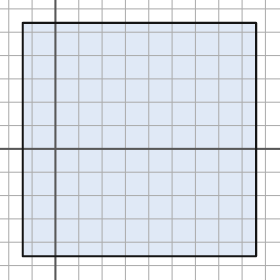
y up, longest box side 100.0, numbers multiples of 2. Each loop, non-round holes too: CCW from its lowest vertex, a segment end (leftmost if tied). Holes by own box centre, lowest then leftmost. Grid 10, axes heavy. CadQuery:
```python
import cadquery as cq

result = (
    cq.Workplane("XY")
    .moveTo(-14.0, -46.0)
    .lineTo(86.0, -46.0)
    .lineTo(86.0, 54.0)
    .lineTo(-14.0, 54.0)
    .close()
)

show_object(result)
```